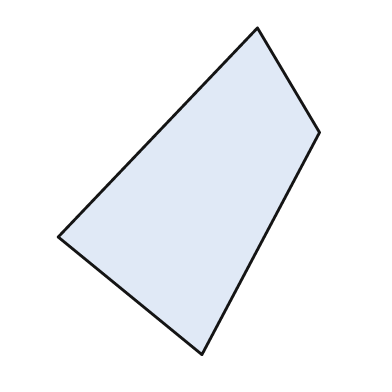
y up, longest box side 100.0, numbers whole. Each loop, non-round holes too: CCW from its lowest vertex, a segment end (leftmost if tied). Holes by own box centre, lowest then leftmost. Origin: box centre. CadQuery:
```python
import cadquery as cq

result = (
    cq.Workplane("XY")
    .moveTo(4.0, -50.0)
    .lineTo(40.0, 18.0)
    .lineTo(21.0, 50.0)
    .lineTo(-40.0, -14.0)
    .close()
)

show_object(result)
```